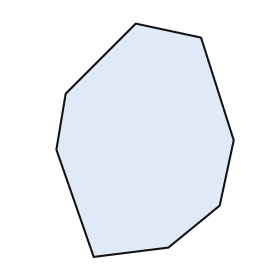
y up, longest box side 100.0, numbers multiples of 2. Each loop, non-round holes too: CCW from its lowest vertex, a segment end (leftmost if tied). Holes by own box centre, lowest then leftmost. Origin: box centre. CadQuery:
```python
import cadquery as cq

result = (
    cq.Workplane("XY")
    .moveTo(-22.0, -50.0)
    .lineTo(10.0, -46.0)
    .lineTo(32.0, -28.0)
    .lineTo(38.0, 0.0)
    .lineTo(24.0, 44.0)
    .lineTo(-4.0, 50.0)
    .lineTo(-34.0, 20.0)
    .lineTo(-38.0, -4.0)
    .close()
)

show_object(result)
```